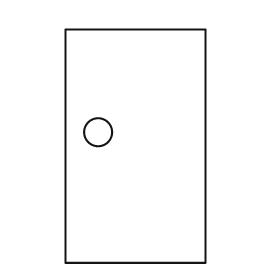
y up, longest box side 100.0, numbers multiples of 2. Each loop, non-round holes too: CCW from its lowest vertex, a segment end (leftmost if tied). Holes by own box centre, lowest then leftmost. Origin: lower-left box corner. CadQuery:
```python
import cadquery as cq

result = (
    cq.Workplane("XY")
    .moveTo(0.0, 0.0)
    .lineTo(60.0, 0.0)
    .lineTo(60.0, 100.0)
    .lineTo(0.0, 100.0)
    .close()
    .moveTo(14.0, 56.0)
    .circle(6.0)
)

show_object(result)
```